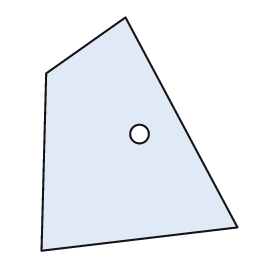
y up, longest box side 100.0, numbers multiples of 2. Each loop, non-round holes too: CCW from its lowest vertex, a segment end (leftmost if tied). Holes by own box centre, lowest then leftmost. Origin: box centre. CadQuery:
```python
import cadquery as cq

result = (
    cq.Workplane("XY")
    .moveTo(-42.0, -50.0)
    .lineTo(42.0, -40.0)
    .lineTo(-6.0, 50.0)
    .lineTo(-40.0, 26.0)
    .close()
    .moveTo(0.0, 0.0)
    .circle(4.0)
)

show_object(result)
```